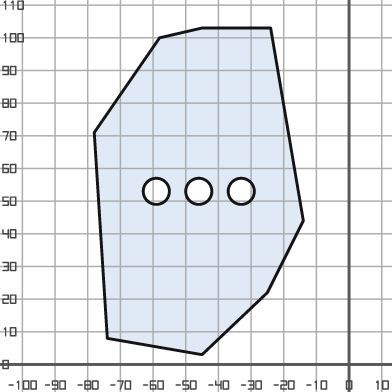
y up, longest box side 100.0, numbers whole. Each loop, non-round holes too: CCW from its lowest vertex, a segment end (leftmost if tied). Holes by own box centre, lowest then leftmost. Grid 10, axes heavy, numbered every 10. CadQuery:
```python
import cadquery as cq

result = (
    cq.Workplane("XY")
    .moveTo(-45.0, 3.0)
    .lineTo(-25.0, 22.0)
    .lineTo(-14.0, 44.0)
    .lineTo(-24.0, 103.0)
    .lineTo(-45.0, 103.0)
    .lineTo(-58.0, 100.0)
    .lineTo(-78.0, 71.0)
    .lineTo(-74.0, 8.0)
    .close()
    .moveTo(-59.0, 53.0)
    .circle(4.0)
    .moveTo(-46.0, 53.0)
    .circle(4.0)
    .moveTo(-33.0, 53.0)
    .circle(4.0)
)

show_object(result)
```